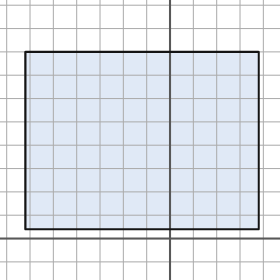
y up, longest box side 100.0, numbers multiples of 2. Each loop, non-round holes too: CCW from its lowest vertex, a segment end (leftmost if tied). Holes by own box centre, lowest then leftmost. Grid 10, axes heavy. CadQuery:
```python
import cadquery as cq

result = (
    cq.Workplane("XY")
    .moveTo(-62.0, 4.0)
    .lineTo(38.0, 4.0)
    .lineTo(38.0, 80.0)
    .lineTo(-62.0, 80.0)
    .close()
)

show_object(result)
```